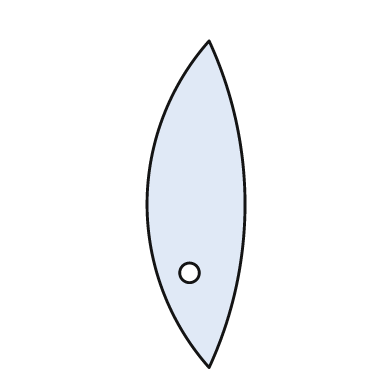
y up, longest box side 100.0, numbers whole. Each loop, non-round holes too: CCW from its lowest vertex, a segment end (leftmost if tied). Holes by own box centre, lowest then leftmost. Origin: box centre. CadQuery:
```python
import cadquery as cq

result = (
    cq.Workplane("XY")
    .moveTo(4.0, -50.0)
    .threePointArc((15.0, 0.0), (4.0, 50.0))
    .threePointArc((-15.0, 0.0), (4.0, -50.0))
    .close()
    .moveTo(-2.0, -21.0)
    .circle(3.0)
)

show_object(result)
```